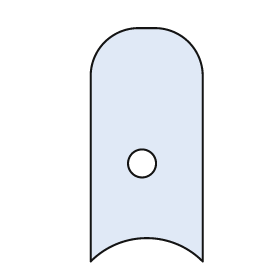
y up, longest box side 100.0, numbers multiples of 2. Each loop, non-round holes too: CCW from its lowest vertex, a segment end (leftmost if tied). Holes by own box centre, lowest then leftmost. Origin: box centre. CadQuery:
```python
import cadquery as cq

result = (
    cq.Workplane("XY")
    .moveTo(-24.0, -50.0)
    .threePointArc((0.0, -40.0), (24.0, -50.0))
    .lineTo(24.0, 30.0)
    .threePointArc((18.0, 44.0), (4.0, 50.0))
    .lineTo(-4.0, 50.0)
    .threePointArc((-18.0, 44.0), (-24.0, 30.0))
    .close()
    .moveTo(-2.0, -8.0)
    .circle(6.0)
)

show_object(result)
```